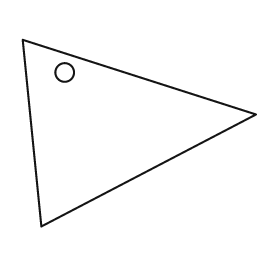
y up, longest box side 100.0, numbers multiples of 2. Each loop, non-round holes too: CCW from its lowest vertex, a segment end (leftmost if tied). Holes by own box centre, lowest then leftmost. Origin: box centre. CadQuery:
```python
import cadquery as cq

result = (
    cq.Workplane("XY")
    .moveTo(-42.0, -40.0)
    .lineTo(50.0, 8.0)
    .lineTo(-50.0, 40.0)
    .close()
    .moveTo(-32.0, 26.0)
    .circle(4.0)
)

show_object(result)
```